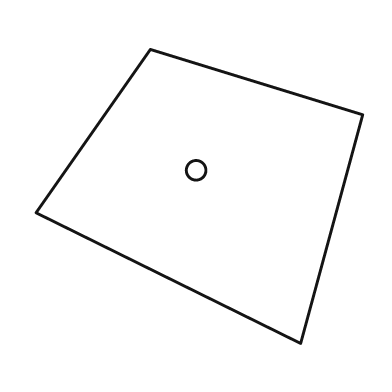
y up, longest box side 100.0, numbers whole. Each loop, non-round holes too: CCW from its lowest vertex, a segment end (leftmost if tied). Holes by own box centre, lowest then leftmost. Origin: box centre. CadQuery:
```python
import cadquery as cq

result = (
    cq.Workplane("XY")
    .moveTo(31.0, -45.0)
    .lineTo(50.0, 25.0)
    .lineTo(-15.0, 45.0)
    .lineTo(-50.0, -5.0)
    .close()
    .moveTo(-1.0, 8.0)
    .circle(3.0)
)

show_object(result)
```